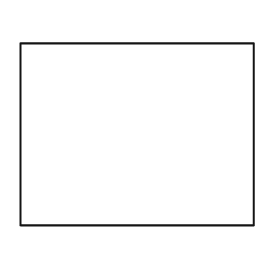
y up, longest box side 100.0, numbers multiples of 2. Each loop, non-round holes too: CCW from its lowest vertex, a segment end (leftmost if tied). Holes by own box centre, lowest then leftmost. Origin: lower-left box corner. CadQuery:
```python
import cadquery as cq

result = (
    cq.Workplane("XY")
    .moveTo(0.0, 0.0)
    .lineTo(100.0, 0.0)
    .lineTo(100.0, 78.0)
    .lineTo(0.0, 78.0)
    .close()
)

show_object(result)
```